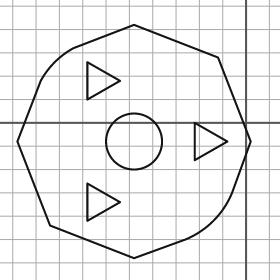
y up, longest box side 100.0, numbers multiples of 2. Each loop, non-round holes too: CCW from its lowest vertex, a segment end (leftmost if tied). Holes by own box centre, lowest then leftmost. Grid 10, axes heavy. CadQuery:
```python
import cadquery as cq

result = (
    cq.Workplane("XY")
    .moveTo(-48.0, -58.0)
    .lineTo(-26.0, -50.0)
    .threePointArc((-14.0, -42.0), (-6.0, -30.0))
    .lineTo(2.0, -8.0)
    .lineTo(-12.0, 28.0)
    .lineTo(-48.0, 42.0)
    .lineTo(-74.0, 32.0)
    .threePointArc((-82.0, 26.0), (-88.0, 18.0))
    .lineTo(-98.0, -8.0)
    .lineTo(-84.0, -44.0)
    .close()
    .moveTo(-68.0, -42.0)
    .lineTo(-54.0, -34.0)
    .lineTo(-68.0, -26.0)
    .close()
    .moveTo(-48.0, -8.0)
    .circle(12.0)
    .moveTo(-22.0, -16.0)
    .lineTo(-8.0, -8.0)
    .lineTo(-22.0, 0.0)
    .close()
    .moveTo(-68.0, 10.0)
    .lineTo(-54.0, 18.0)
    .lineTo(-68.0, 26.0)
    .close()
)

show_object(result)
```